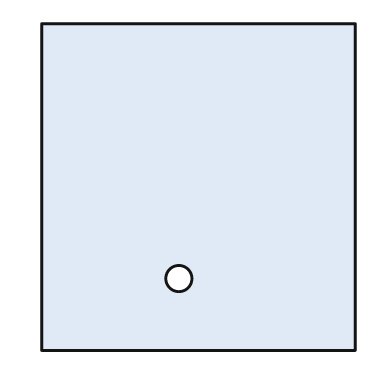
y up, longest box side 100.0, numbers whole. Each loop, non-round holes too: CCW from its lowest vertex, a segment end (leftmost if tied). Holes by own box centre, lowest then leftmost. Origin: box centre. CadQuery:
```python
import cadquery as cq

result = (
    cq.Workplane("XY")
    .moveTo(-48.0, -50.0)
    .lineTo(48.0, -50.0)
    .lineTo(48.0, 50.0)
    .lineTo(-48.0, 50.0)
    .close()
    .moveTo(-6.0, -28.0)
    .circle(4.0)
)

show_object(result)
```